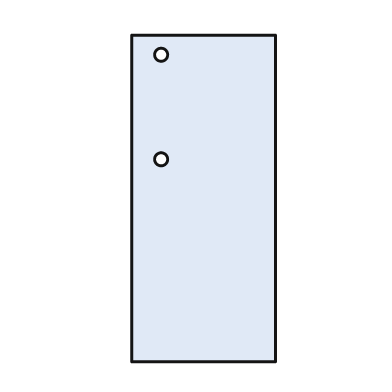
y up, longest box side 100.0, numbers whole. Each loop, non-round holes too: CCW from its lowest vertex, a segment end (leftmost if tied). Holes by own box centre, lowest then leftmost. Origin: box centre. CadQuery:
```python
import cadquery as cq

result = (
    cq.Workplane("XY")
    .moveTo(-22.0, -50.0)
    .lineTo(22.0, -50.0)
    .lineTo(22.0, 50.0)
    .lineTo(-22.0, 50.0)
    .close()
    .moveTo(-13.0, 12.0)
    .circle(2.0)
    .moveTo(-13.0, 44.0)
    .circle(2.0)
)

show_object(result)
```